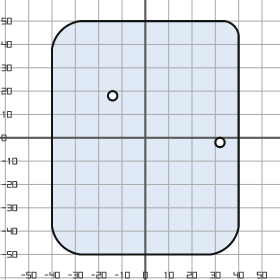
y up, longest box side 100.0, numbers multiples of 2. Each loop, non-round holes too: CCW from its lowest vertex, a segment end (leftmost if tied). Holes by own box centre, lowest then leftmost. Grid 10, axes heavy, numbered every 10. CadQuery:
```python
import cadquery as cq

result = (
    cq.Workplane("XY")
    .moveTo(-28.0, -50.0)
    .lineTo(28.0, -50.0)
    .threePointArc((36.0, -46.0), (40.0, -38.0))
    .lineTo(40.0, 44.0)
    .threePointArc((38.0, 48.0), (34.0, 50.0))
    .lineTo(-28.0, 50.0)
    .threePointArc((-36.0, 46.0), (-40.0, 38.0))
    .lineTo(-40.0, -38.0)
    .threePointArc((-36.0, -46.0), (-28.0, -50.0))
    .close()
    .moveTo(32.0, -2.0)
    .circle(2.0)
    .moveTo(-14.0, 18.0)
    .circle(2.0)
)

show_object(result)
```